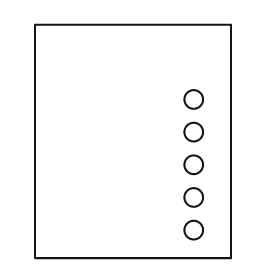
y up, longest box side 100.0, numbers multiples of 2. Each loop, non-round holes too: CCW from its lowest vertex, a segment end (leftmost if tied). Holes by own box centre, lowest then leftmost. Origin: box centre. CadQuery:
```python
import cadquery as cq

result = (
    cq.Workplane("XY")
    .moveTo(-42.0, -50.0)
    .lineTo(42.0, -50.0)
    .lineTo(42.0, 50.0)
    .lineTo(-42.0, 50.0)
    .close()
    .moveTo(26.0, -38.0)
    .circle(4.0)
    .moveTo(26.0, -24.0)
    .circle(4.0)
    .moveTo(26.0, -10.0)
    .circle(4.0)
    .moveTo(26.0, 4.0)
    .circle(4.0)
    .moveTo(26.0, 18.0)
    .circle(4.0)
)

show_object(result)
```